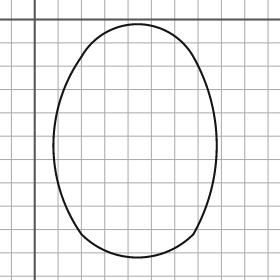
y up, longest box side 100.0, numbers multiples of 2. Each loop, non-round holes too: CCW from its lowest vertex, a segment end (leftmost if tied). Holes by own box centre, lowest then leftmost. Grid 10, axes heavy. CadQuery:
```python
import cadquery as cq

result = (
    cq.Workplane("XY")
    .moveTo(20.0, -92.0)
    .threePointArc((44.0, -102.0), (68.0, -92.0))
    .threePointArc((78.0, -54.0), (68.0, -16.0))
    .threePointArc((44.0, -2.0), (20.0, -16.0))
    .threePointArc((8.0, -54.0), (20.0, -92.0))
    .close()
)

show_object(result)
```